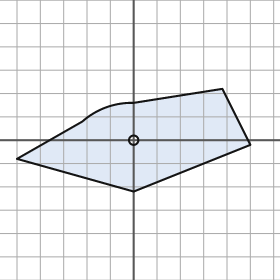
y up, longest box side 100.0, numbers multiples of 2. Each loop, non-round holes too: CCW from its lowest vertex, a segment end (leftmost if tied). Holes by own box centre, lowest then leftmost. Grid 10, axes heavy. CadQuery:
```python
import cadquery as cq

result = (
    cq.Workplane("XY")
    .moveTo(0.0, -22.0)
    .lineTo(50.0, -2.0)
    .lineTo(38.0, 22.0)
    .lineTo(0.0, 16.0)
    .threePointArc((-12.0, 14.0), (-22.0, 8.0))
    .lineTo(-50.0, -8.0)
    .close()
    .moveTo(0.0, 0.0)
    .circle(2.0)
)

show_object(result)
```